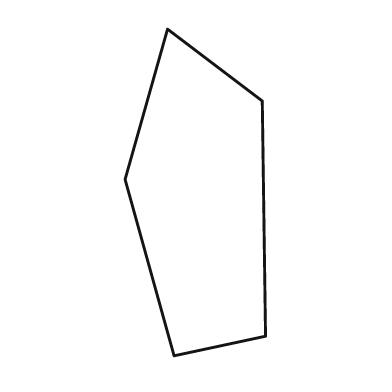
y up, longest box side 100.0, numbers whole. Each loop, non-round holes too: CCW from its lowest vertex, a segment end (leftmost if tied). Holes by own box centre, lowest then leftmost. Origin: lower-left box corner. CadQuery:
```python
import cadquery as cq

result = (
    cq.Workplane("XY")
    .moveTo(15.0, 0.0)
    .lineTo(43.0, 6.0)
    .lineTo(42.0, 78.0)
    .lineTo(13.0, 100.0)
    .lineTo(0.0, 54.0)
    .close()
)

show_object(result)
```